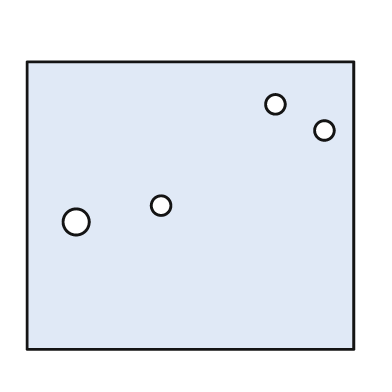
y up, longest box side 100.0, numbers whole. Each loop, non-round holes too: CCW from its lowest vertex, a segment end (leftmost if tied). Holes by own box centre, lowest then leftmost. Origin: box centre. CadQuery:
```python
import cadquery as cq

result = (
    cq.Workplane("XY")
    .moveTo(-50.0, -44.0)
    .lineTo(50.0, -44.0)
    .lineTo(50.0, 44.0)
    .lineTo(-50.0, 44.0)
    .close()
    .moveTo(-35.0, -5.0)
    .circle(4.0)
    .moveTo(-9.0, 0.0)
    .circle(3.0)
    .moveTo(41.0, 23.0)
    .circle(3.0)
    .moveTo(26.0, 31.0)
    .circle(3.0)
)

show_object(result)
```